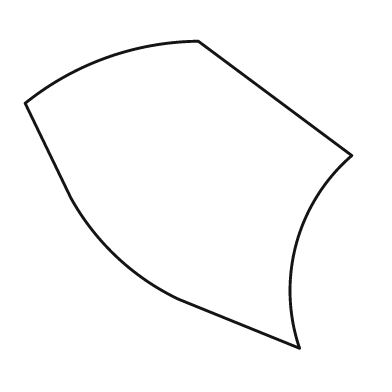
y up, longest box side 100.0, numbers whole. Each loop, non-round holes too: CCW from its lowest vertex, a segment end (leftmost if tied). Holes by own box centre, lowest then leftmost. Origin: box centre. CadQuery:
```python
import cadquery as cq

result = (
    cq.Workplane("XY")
    .moveTo(34.0, -47.0)
    .threePointArc((33.0, -15.0), (50.0, 12.0))
    .lineTo(3.0, 47.0)
    .threePointArc((-25.0, 42.0), (-50.0, 28.0))
    .lineTo(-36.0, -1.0)
    .threePointArc((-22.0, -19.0), (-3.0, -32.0))
    .close()
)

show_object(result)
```